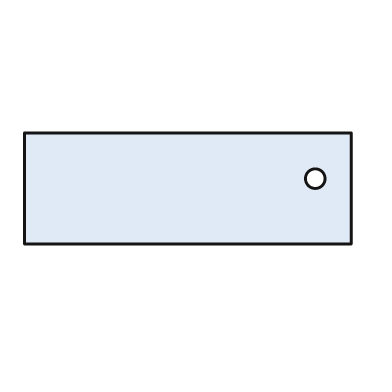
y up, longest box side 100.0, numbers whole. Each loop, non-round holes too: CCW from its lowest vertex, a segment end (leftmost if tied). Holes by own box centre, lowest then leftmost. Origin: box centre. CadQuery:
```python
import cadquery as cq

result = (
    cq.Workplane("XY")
    .moveTo(-50.0, -17.0)
    .lineTo(50.0, -17.0)
    .lineTo(50.0, 17.0)
    .lineTo(-50.0, 17.0)
    .close()
    .moveTo(39.0, 3.0)
    .circle(3.0)
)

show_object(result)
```